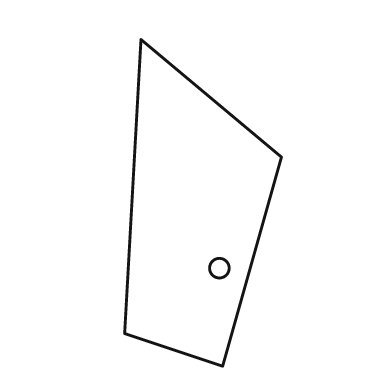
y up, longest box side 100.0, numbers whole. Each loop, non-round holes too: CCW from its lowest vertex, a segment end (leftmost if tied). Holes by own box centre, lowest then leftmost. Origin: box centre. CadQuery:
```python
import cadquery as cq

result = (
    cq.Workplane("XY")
    .moveTo(6.0, -50.0)
    .lineTo(24.0, 14.0)
    .lineTo(-19.0, 50.0)
    .lineTo(-24.0, -40.0)
    .close()
    .moveTo(5.0, -20.0)
    .circle(3.0)
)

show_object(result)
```